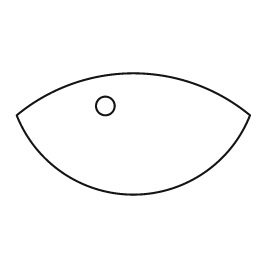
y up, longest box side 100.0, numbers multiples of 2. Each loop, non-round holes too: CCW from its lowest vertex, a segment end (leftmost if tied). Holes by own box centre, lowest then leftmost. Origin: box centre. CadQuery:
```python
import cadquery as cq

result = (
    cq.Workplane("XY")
    .moveTo(-50.0, 8.0)
    .threePointArc((0.0, -26.0), (50.0, 8.0))
    .threePointArc((0.0, 26.0), (-50.0, 8.0))
    .close()
    .moveTo(-12.0, 12.0)
    .circle(4.0)
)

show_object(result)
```